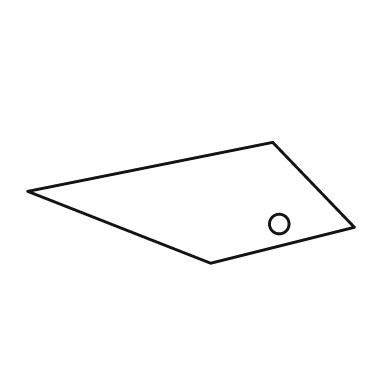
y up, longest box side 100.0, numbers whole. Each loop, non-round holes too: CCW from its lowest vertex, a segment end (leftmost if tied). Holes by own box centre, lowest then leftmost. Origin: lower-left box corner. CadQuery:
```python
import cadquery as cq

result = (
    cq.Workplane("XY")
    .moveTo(56.0, 0.0)
    .lineTo(100.0, 11.0)
    .lineTo(75.0, 37.0)
    .lineTo(0.0, 22.0)
    .close()
    .moveTo(77.0, 12.0)
    .circle(3.0)
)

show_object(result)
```